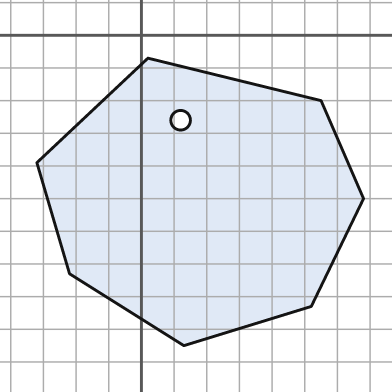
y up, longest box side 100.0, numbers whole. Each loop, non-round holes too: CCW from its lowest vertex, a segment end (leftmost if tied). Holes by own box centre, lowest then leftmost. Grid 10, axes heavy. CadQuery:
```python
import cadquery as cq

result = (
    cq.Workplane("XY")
    .moveTo(13.0, -95.0)
    .lineTo(52.0, -83.0)
    .lineTo(68.0, -50.0)
    .lineTo(55.0, -20.0)
    .lineTo(2.0, -7.0)
    .lineTo(-32.0, -39.0)
    .lineTo(-22.0, -73.0)
    .close()
    .moveTo(12.0, -26.0)
    .circle(3.0)
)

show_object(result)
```